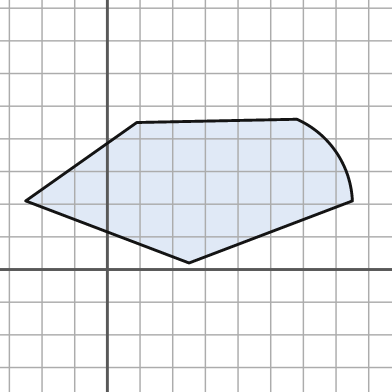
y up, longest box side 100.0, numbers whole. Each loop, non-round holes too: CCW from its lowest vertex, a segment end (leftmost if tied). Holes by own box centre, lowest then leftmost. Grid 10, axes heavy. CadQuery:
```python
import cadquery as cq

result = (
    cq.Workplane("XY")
    .moveTo(25.0, 2.0)
    .lineTo(75.0, 21.0)
    .threePointArc((70.0, 36.0), (58.0, 46.0))
    .lineTo(9.0, 45.0)
    .lineTo(-25.0, 21.0)
    .close()
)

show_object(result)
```